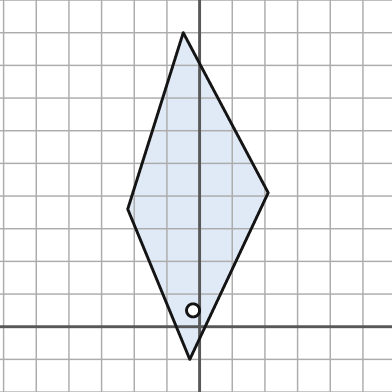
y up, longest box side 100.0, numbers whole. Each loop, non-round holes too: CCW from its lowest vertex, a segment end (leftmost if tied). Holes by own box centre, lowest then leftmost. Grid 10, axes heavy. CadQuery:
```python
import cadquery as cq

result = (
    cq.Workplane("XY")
    .moveTo(-3.0, -10.0)
    .lineTo(21.0, 41.0)
    .lineTo(-5.0, 90.0)
    .lineTo(-22.0, 36.0)
    .close()
    .moveTo(-2.0, 5.0)
    .circle(2.0)
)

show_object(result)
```